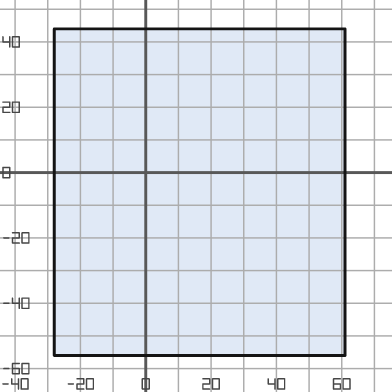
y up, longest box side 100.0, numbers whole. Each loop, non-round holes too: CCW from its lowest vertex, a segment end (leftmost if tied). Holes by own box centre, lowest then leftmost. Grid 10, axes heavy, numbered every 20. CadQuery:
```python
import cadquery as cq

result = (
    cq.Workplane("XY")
    .moveTo(-28.0, -56.0)
    .lineTo(61.0, -56.0)
    .lineTo(61.0, 44.0)
    .lineTo(-28.0, 44.0)
    .close()
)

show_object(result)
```